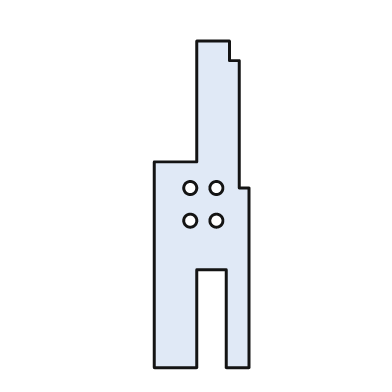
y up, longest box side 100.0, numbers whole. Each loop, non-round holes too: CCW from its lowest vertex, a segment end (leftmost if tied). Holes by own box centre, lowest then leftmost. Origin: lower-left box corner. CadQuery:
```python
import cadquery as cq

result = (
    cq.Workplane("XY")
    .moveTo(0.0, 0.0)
    .lineTo(13.0, 0.0)
    .lineTo(13.0, 30.0)
    .lineTo(22.0, 30.0)
    .lineTo(22.0, 0.0)
    .lineTo(29.0, 0.0)
    .lineTo(29.0, 55.0)
    .lineTo(26.0, 55.0)
    .lineTo(26.0, 94.0)
    .lineTo(23.0, 94.0)
    .lineTo(23.0, 100.0)
    .lineTo(13.0, 100.0)
    .lineTo(13.0, 63.0)
    .lineTo(0.0, 63.0)
    .close()
    .moveTo(11.0, 45.0)
    .circle(2.0)
    .moveTo(19.0, 45.0)
    .circle(2.0)
    .moveTo(11.0, 55.0)
    .circle(2.0)
    .moveTo(19.0, 55.0)
    .circle(2.0)
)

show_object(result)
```